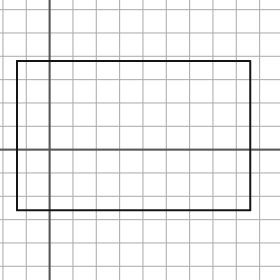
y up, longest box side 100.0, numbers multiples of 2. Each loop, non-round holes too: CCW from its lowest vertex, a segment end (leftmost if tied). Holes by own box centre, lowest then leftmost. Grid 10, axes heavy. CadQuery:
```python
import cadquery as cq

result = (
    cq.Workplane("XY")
    .moveTo(-14.0, -26.0)
    .lineTo(86.0, -26.0)
    .lineTo(86.0, 38.0)
    .lineTo(-14.0, 38.0)
    .close()
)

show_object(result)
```